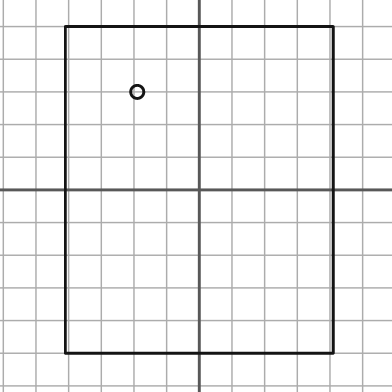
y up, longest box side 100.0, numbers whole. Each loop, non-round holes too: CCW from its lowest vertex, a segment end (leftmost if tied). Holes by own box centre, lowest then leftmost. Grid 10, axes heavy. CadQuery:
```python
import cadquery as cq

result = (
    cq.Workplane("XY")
    .moveTo(-41.0, -50.0)
    .lineTo(41.0, -50.0)
    .lineTo(41.0, 50.0)
    .lineTo(-41.0, 50.0)
    .close()
    .moveTo(-19.0, 30.0)
    .circle(2.0)
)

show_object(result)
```